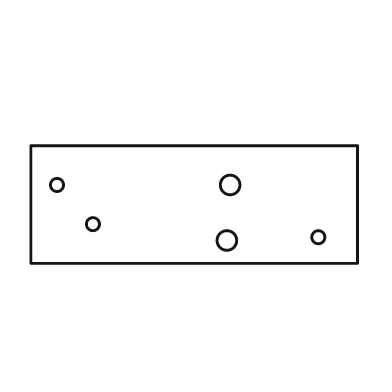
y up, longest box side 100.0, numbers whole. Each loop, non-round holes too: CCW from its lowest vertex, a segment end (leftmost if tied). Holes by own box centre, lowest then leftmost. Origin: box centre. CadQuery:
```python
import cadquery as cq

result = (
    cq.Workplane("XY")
    .moveTo(-50.0, -18.0)
    .lineTo(50.0, -18.0)
    .lineTo(50.0, 18.0)
    .lineTo(-50.0, 18.0)
    .close()
    .moveTo(10.0, -11.0)
    .circle(3.0)
    .moveTo(38.0, -10.0)
    .circle(2.0)
    .moveTo(-31.0, -6.0)
    .circle(2.0)
    .moveTo(-42.0, 6.0)
    .circle(2.0)
    .moveTo(11.0, 6.0)
    .circle(3.0)
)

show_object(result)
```